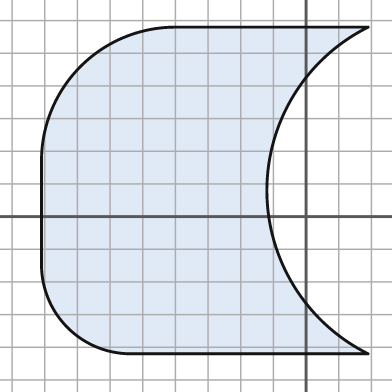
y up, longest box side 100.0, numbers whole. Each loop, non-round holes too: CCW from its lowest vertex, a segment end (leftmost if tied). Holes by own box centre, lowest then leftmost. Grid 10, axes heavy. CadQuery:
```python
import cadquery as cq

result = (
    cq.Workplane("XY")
    .moveTo(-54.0, -42.0)
    .lineTo(19.0, -42.0)
    .threePointArc((-12.0, 8.0), (19.0, 58.0))
    .lineTo(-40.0, 58.0)
    .threePointArc((-69.0, 46.0), (-81.0, 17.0))
    .lineTo(-81.0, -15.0)
    .threePointArc((-73.0, -34.0), (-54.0, -42.0))
    .close()
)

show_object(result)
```